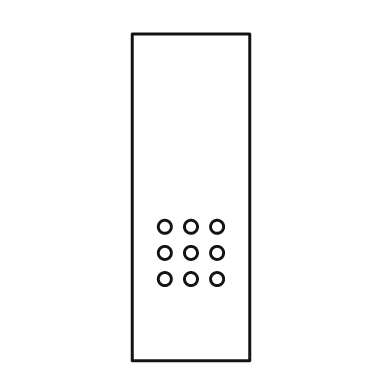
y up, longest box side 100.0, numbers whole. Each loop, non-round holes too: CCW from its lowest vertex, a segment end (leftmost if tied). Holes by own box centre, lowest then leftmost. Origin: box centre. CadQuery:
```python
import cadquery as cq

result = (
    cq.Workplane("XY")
    .moveTo(-18.0, -50.0)
    .lineTo(18.0, -50.0)
    .lineTo(18.0, 50.0)
    .lineTo(-18.0, 50.0)
    .close()
    .moveTo(-8.0, -25.0)
    .circle(2.0)
    .moveTo(0.0, -25.0)
    .circle(2.0)
    .moveTo(8.0, -25.0)
    .circle(2.0)
    .moveTo(-8.0, -17.0)
    .circle(2.0)
    .moveTo(0.0, -17.0)
    .circle(2.0)
    .moveTo(8.0, -17.0)
    .circle(2.0)
    .moveTo(-8.0, -9.0)
    .circle(2.0)
    .moveTo(0.0, -9.0)
    .circle(2.0)
    .moveTo(8.0, -9.0)
    .circle(2.0)
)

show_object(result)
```